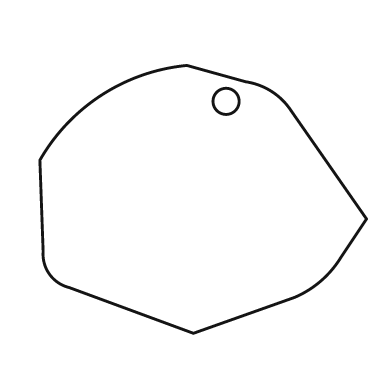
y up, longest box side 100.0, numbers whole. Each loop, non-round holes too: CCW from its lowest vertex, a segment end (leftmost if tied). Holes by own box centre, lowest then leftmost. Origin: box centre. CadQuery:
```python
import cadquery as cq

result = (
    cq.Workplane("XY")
    .moveTo(-3.0, -41.0)
    .lineTo(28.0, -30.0)
    .threePointArc((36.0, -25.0), (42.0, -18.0))
    .lineTo(50.0, -6.0)
    .lineTo(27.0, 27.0)
    .threePointArc((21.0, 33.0), (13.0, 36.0))
    .lineTo(-5.0, 41.0)
    .threePointArc((-31.0, 32.0), (-50.0, 12.0))
    .lineTo(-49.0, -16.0)
    .threePointArc((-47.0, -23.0), (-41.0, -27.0))
    .close()
    .moveTo(7.0, 30.0)
    .circle(4.0)
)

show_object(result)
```